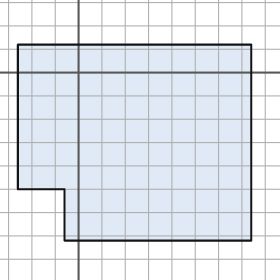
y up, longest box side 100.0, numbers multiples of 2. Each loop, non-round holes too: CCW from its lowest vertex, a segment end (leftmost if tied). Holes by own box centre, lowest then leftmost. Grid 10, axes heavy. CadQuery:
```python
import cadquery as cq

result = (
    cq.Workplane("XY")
    .moveTo(-6.0, -72.0)
    .lineTo(74.0, -72.0)
    .lineTo(74.0, 12.0)
    .lineTo(-26.0, 12.0)
    .lineTo(-26.0, -50.0)
    .lineTo(-6.0, -50.0)
    .close()
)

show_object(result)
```